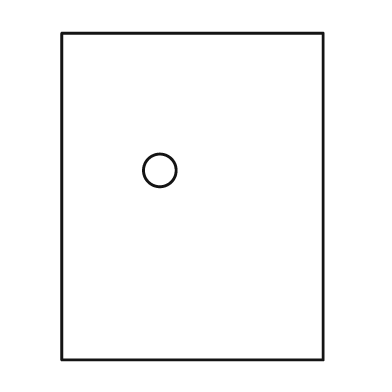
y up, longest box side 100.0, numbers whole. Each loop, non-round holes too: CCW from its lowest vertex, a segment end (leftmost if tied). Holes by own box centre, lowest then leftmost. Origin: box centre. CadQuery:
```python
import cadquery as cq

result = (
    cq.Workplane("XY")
    .moveTo(-40.0, -50.0)
    .lineTo(40.0, -50.0)
    .lineTo(40.0, 50.0)
    .lineTo(-40.0, 50.0)
    .close()
    .moveTo(-10.0, 8.0)
    .circle(5.0)
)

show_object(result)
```